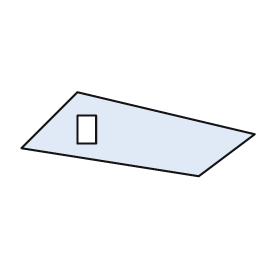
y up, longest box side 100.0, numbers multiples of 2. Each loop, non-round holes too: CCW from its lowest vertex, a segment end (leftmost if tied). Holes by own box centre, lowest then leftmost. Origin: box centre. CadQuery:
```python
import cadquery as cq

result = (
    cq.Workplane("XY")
    .moveTo(26.0, -18.0)
    .lineTo(50.0, 0.0)
    .lineTo(-26.0, 18.0)
    .lineTo(-50.0, -6.0)
    .close()
    .moveTo(-26.0, -4.0)
    .lineTo(-18.0, -4.0)
    .lineTo(-18.0, 8.0)
    .lineTo(-26.0, 8.0)
    .close()
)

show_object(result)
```